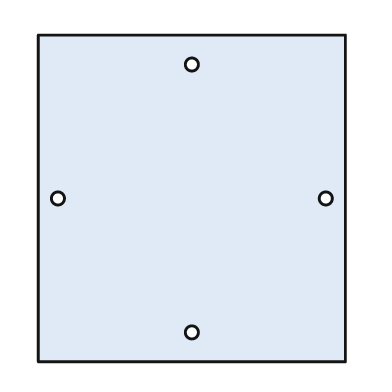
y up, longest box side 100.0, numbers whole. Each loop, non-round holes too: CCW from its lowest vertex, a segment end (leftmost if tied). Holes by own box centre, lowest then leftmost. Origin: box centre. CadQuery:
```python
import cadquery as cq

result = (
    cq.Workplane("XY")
    .moveTo(-47.0, -50.0)
    .lineTo(47.0, -50.0)
    .lineTo(47.0, 50.0)
    .lineTo(-47.0, 50.0)
    .close()
    .moveTo(0.0, -41.0)
    .circle(2.0)
    .moveTo(-41.0, 0.0)
    .circle(2.0)
    .moveTo(41.0, 0.0)
    .circle(2.0)
    .moveTo(0.0, 41.0)
    .circle(2.0)
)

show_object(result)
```